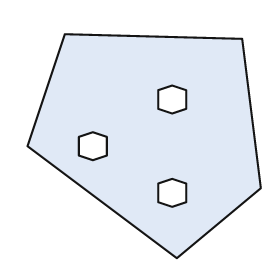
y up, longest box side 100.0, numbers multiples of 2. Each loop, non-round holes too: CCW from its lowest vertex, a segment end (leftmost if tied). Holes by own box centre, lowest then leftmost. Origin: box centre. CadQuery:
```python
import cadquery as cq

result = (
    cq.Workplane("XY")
    .moveTo(14.0, -48.0)
    .lineTo(50.0, -18.0)
    .lineTo(42.0, 46.0)
    .lineTo(-34.0, 48.0)
    .lineTo(-50.0, 0.0)
    .close()
    .moveTo(12.0, -26.0)
    .lineTo(18.0, -24.0)
    .lineTo(18.0, -16.0)
    .lineTo(12.0, -14.0)
    .lineTo(6.0, -16.0)
    .lineTo(6.0, -24.0)
    .close()
    .moveTo(-22.0, -6.0)
    .lineTo(-16.0, -4.0)
    .lineTo(-16.0, 4.0)
    .lineTo(-22.0, 6.0)
    .lineTo(-28.0, 4.0)
    .lineTo(-28.0, -4.0)
    .close()
    .moveTo(12.0, 14.0)
    .lineTo(18.0, 16.0)
    .lineTo(18.0, 24.0)
    .lineTo(12.0, 26.0)
    .lineTo(6.0, 24.0)
    .lineTo(6.0, 16.0)
    .close()
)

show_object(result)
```